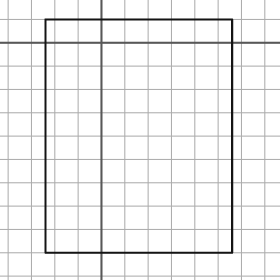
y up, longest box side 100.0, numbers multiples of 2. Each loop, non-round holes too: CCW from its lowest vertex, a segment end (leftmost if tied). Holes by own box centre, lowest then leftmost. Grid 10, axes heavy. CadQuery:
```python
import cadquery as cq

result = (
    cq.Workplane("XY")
    .moveTo(-24.0, -90.0)
    .lineTo(56.0, -90.0)
    .lineTo(56.0, 10.0)
    .lineTo(-24.0, 10.0)
    .close()
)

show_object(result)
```